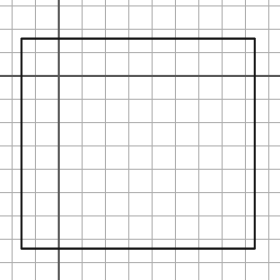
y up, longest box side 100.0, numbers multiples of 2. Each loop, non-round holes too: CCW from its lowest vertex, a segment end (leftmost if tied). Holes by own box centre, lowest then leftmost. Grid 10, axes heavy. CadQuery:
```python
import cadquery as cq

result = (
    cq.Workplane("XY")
    .moveTo(-16.0, -74.0)
    .lineTo(84.0, -74.0)
    .lineTo(84.0, 16.0)
    .lineTo(-16.0, 16.0)
    .close()
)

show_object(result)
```